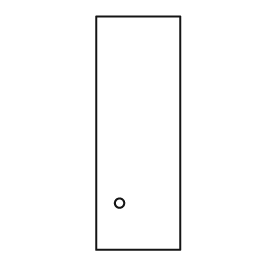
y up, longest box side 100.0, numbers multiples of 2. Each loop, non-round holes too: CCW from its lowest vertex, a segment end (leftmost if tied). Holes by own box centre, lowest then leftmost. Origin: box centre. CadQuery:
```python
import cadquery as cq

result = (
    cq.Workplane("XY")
    .moveTo(-18.0, -50.0)
    .lineTo(18.0, -50.0)
    .lineTo(18.0, 50.0)
    .lineTo(-18.0, 50.0)
    .close()
    .moveTo(-8.0, -30.0)
    .circle(2.0)
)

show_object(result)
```